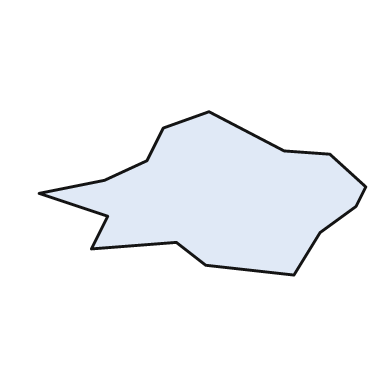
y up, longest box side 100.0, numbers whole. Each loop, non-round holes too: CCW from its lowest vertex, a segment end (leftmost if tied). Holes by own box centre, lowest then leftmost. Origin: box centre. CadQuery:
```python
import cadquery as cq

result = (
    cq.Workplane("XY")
    .moveTo(28.0, -25.0)
    .lineTo(36.0, -12.0)
    .lineTo(47.0, -4.0)
    .lineTo(50.0, 2.0)
    .lineTo(39.0, 12.0)
    .lineTo(25.0, 13.0)
    .lineTo(2.0, 25.0)
    .lineTo(-12.0, 20.0)
    .lineTo(-17.0, 10.0)
    .lineTo(-30.0, 4.0)
    .lineTo(-50.0, 0.0)
    .lineTo(-29.0, -7.0)
    .lineTo(-34.0, -17.0)
    .lineTo(-8.0, -15.0)
    .lineTo(1.0, -22.0)
    .close()
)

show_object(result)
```